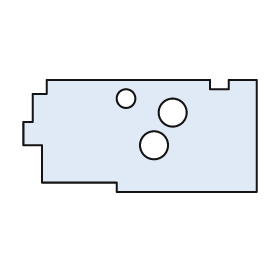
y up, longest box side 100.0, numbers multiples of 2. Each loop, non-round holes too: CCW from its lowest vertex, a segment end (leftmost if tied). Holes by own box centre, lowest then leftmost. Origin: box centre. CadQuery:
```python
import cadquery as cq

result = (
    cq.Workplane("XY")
    .moveTo(-10.0, -24.0)
    .lineTo(50.0, -24.0)
    .lineTo(50.0, 24.0)
    .lineTo(38.0, 24.0)
    .lineTo(38.0, 20.0)
    .lineTo(30.0, 20.0)
    .lineTo(30.0, 24.0)
    .lineTo(-40.0, 24.0)
    .lineTo(-40.0, 18.0)
    .lineTo(-46.0, 18.0)
    .lineTo(-46.0, 6.0)
    .lineTo(-50.0, 6.0)
    .lineTo(-50.0, -4.0)
    .lineTo(-42.0, -4.0)
    .lineTo(-42.0, -20.0)
    .lineTo(-10.0, -20.0)
    .close()
    .moveTo(6.0, -4.0)
    .circle(6.0)
    .moveTo(14.0, 10.0)
    .circle(6.0)
    .moveTo(-6.0, 16.0)
    .circle(4.0)
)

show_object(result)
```